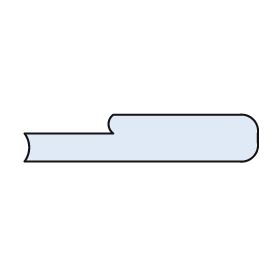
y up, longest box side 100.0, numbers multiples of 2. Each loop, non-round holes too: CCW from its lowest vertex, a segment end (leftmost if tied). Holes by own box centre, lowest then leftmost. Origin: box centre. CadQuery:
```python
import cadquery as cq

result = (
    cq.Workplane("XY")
    .moveTo(-50.0, -10.0)
    .lineTo(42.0, -10.0)
    .threePointArc((48.0, -8.0), (50.0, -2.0))
    .lineTo(50.0, 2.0)
    .threePointArc((48.0, 8.0), (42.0, 10.0))
    .lineTo(-12.0, 10.0)
    .threePointArc((-14.0, 6.0), (-12.0, 2.0))
    .lineTo(-50.0, 2.0)
    .threePointArc((-48.0, -4.0), (-50.0, -10.0))
    .close()
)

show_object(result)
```